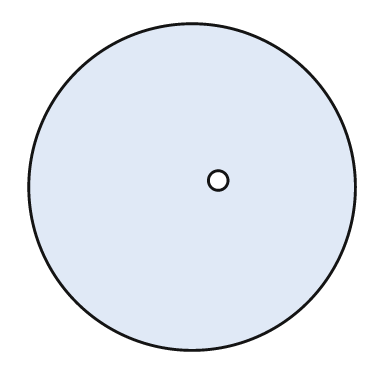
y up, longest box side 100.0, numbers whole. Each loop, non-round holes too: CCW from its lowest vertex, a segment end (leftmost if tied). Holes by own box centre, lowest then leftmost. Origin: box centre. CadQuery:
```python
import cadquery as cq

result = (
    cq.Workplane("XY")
    .moveTo(0.0, 0.0)
    .circle(50.0)
    .moveTo(8.0, 2.0)
    .circle(3.0)
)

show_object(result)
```